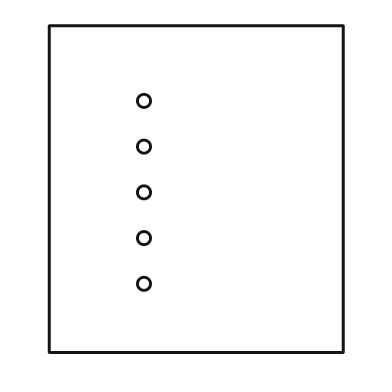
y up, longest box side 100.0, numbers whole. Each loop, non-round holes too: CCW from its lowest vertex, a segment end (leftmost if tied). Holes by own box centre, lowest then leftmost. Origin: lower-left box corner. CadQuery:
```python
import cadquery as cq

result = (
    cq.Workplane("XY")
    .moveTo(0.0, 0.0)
    .lineTo(90.0, 0.0)
    .lineTo(90.0, 100.0)
    .lineTo(0.0, 100.0)
    .close()
    .moveTo(29.0, 21.0)
    .circle(2.0)
    .moveTo(29.0, 35.0)
    .circle(2.0)
    .moveTo(29.0, 49.0)
    .circle(2.0)
    .moveTo(29.0, 63.0)
    .circle(2.0)
    .moveTo(29.0, 77.0)
    .circle(2.0)
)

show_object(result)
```